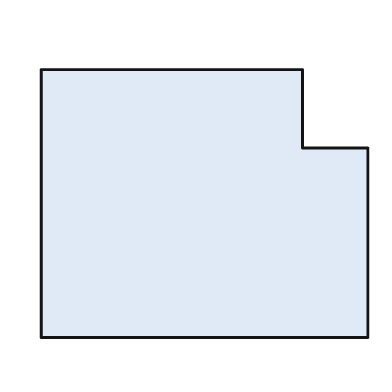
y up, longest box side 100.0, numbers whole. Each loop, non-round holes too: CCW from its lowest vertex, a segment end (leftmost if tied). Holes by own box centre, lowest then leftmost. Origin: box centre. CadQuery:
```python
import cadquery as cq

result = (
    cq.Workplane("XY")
    .moveTo(-50.0, -41.0)
    .lineTo(50.0, -41.0)
    .lineTo(50.0, 17.0)
    .lineTo(30.0, 17.0)
    .lineTo(30.0, 41.0)
    .lineTo(-50.0, 41.0)
    .close()
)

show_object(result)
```